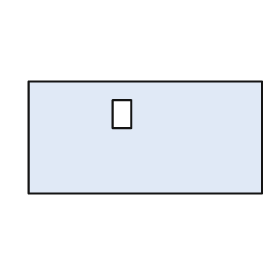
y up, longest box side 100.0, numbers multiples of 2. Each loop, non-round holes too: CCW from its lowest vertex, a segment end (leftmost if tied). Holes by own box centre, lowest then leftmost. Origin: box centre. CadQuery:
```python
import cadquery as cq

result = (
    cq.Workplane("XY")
    .moveTo(-50.0, -24.0)
    .lineTo(50.0, -24.0)
    .lineTo(50.0, 24.0)
    .lineTo(-50.0, 24.0)
    .close()
    .moveTo(-14.0, 4.0)
    .lineTo(-6.0, 4.0)
    .lineTo(-6.0, 16.0)
    .lineTo(-14.0, 16.0)
    .close()
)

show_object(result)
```